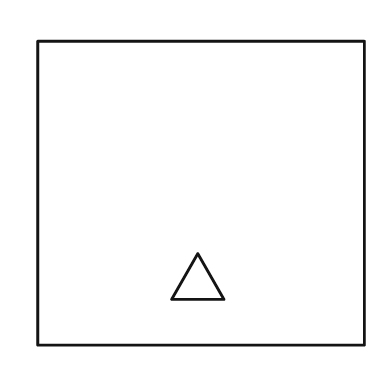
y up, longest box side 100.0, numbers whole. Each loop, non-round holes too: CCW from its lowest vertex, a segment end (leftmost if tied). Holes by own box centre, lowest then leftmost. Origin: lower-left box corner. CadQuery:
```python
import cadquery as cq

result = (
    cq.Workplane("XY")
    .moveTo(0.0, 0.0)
    .lineTo(100.0, 0.0)
    .lineTo(100.0, 93.0)
    .lineTo(0.0, 93.0)
    .close()
    .moveTo(41.0, 14.0)
    .lineTo(57.0, 14.0)
    .lineTo(49.0, 28.0)
    .close()
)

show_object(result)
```